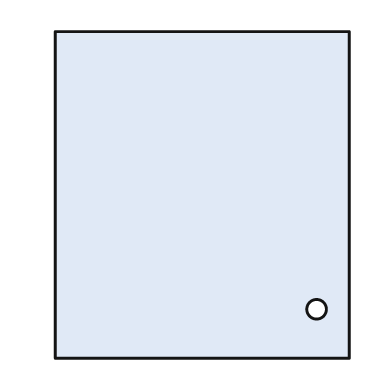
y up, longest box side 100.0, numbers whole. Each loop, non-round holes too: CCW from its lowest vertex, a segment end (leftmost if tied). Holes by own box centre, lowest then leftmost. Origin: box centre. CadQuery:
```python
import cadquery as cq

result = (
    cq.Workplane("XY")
    .moveTo(-45.0, -50.0)
    .lineTo(45.0, -50.0)
    .lineTo(45.0, 50.0)
    .lineTo(-45.0, 50.0)
    .close()
    .moveTo(35.0, -35.0)
    .circle(3.0)
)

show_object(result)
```